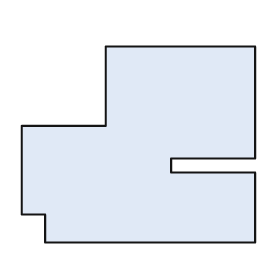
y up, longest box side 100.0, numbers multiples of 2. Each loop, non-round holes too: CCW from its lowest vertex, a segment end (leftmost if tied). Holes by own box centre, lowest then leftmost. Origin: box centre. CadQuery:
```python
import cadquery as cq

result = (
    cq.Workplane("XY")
    .moveTo(-40.0, -42.0)
    .lineTo(50.0, -42.0)
    .lineTo(50.0, -12.0)
    .lineTo(14.0, -12.0)
    .lineTo(14.0, -6.0)
    .lineTo(50.0, -6.0)
    .lineTo(50.0, 42.0)
    .lineTo(-14.0, 42.0)
    .lineTo(-14.0, 8.0)
    .lineTo(-50.0, 8.0)
    .lineTo(-50.0, -30.0)
    .lineTo(-40.0, -30.0)
    .close()
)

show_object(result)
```